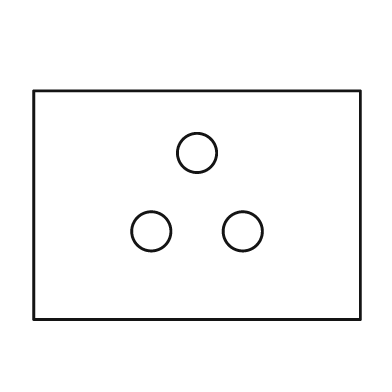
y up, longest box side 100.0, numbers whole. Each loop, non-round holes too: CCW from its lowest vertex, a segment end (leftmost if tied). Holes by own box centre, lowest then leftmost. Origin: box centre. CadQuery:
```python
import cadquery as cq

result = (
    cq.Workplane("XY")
    .moveTo(-50.0, -35.0)
    .lineTo(50.0, -35.0)
    .lineTo(50.0, 35.0)
    .lineTo(-50.0, 35.0)
    .close()
    .moveTo(-14.0, -8.0)
    .circle(6.0)
    .moveTo(14.0, -8.0)
    .circle(6.0)
    .moveTo(0.0, 16.0)
    .circle(6.0)
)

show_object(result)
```